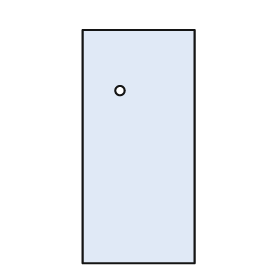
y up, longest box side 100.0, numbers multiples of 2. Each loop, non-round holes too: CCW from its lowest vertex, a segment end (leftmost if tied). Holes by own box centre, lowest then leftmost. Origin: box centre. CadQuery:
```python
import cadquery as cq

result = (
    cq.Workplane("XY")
    .moveTo(-24.0, -50.0)
    .lineTo(24.0, -50.0)
    .lineTo(24.0, 50.0)
    .lineTo(-24.0, 50.0)
    .close()
    .moveTo(-8.0, 24.0)
    .circle(2.0)
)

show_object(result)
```